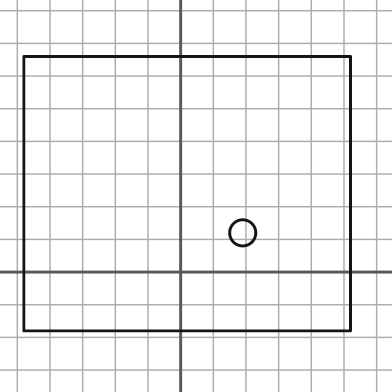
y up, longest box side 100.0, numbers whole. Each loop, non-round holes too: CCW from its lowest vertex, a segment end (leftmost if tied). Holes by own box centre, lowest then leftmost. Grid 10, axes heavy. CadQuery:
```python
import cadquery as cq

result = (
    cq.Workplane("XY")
    .moveTo(-48.0, -18.0)
    .lineTo(52.0, -18.0)
    .lineTo(52.0, 66.0)
    .lineTo(-48.0, 66.0)
    .close()
    .moveTo(19.0, 12.0)
    .circle(4.0)
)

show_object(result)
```